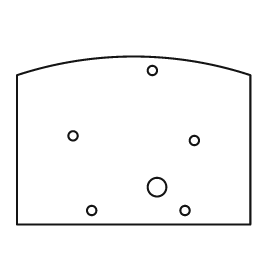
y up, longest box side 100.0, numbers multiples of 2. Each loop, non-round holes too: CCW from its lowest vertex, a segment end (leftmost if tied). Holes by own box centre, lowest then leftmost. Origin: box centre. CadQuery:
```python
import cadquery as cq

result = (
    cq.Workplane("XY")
    .moveTo(-50.0, -36.0)
    .lineTo(50.0, -36.0)
    .lineTo(50.0, 28.0)
    .threePointArc((0.0, 36.0), (-50.0, 28.0))
    .close()
    .moveTo(-18.0, -30.0)
    .circle(2.0)
    .moveTo(22.0, -30.0)
    .circle(2.0)
    .moveTo(10.0, -20.0)
    .circle(4.0)
    .moveTo(26.0, 0.0)
    .circle(2.0)
    .moveTo(-26.0, 2.0)
    .circle(2.0)
    .moveTo(8.0, 30.0)
    .circle(2.0)
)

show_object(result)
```